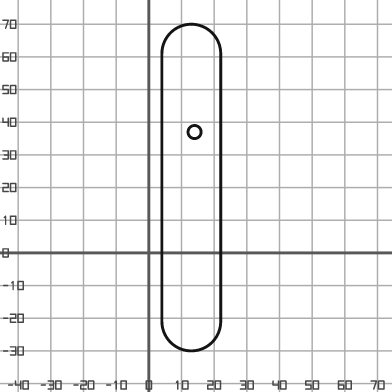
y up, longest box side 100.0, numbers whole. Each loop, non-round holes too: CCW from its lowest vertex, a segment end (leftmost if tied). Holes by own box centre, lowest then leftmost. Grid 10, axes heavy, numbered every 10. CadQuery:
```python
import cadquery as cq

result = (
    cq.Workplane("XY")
    .moveTo(4.0, -21.0)
    .threePointArc((13.0, -30.0), (22.0, -21.0))
    .lineTo(22.0, 61.0)
    .threePointArc((13.0, 70.0), (4.0, 61.0))
    .close()
    .moveTo(14.0, 37.0)
    .circle(2.0)
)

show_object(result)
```